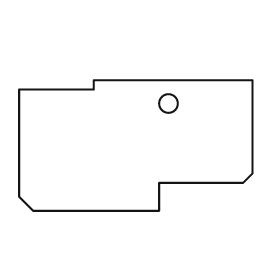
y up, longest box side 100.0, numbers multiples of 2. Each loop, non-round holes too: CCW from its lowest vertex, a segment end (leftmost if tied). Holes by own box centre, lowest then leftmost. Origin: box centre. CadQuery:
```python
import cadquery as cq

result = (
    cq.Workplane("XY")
    .moveTo(-44.0, -28.0)
    .lineTo(10.0, -28.0)
    .lineTo(10.0, -16.0)
    .lineTo(46.0, -16.0)
    .lineTo(50.0, -12.0)
    .lineTo(50.0, 28.0)
    .lineTo(-18.0, 28.0)
    .lineTo(-18.0, 24.0)
    .lineTo(-50.0, 24.0)
    .lineTo(-50.0, -22.0)
    .close()
    .moveTo(14.0, 18.0)
    .circle(4.0)
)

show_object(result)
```